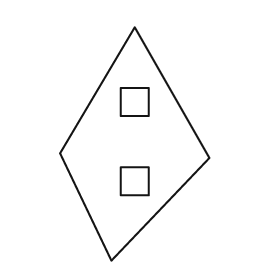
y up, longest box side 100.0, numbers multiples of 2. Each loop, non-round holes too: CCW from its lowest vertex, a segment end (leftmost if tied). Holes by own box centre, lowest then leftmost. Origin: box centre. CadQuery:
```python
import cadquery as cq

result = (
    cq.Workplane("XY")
    .moveTo(-10.0, -50.0)
    .lineTo(32.0, -6.0)
    .lineTo(0.0, 50.0)
    .lineTo(-32.0, -4.0)
    .close()
    .moveTo(-6.0, -22.0)
    .lineTo(6.0, -22.0)
    .lineTo(6.0, -10.0)
    .lineTo(-6.0, -10.0)
    .close()
    .moveTo(-6.0, 12.0)
    .lineTo(6.0, 12.0)
    .lineTo(6.0, 24.0)
    .lineTo(-6.0, 24.0)
    .close()
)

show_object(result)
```